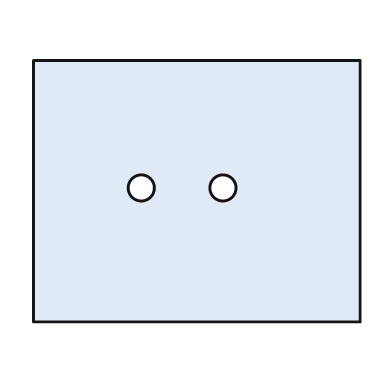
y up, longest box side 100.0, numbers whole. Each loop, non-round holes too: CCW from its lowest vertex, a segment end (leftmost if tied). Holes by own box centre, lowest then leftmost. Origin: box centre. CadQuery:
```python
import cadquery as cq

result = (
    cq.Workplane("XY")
    .moveTo(-50.0, -40.0)
    .lineTo(50.0, -40.0)
    .lineTo(50.0, 40.0)
    .lineTo(-50.0, 40.0)
    .close()
    .moveTo(-17.0, 1.0)
    .circle(4.0)
    .moveTo(8.0, 1.0)
    .circle(4.0)
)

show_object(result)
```